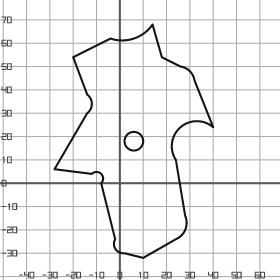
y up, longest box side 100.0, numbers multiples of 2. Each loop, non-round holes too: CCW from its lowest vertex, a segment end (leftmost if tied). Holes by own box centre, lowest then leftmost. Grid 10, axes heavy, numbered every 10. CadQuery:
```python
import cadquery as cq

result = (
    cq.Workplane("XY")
    .moveTo(10.0, -32.0)
    .lineTo(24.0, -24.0)
    .threePointArc((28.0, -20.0), (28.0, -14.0))
    .lineTo(24.0, 10.0)
    .threePointArc((26.0, 24.0), (40.0, 24.0))
    .lineTo(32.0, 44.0)
    .threePointArc((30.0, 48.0), (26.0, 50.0))
    .lineTo(18.0, 54.0)
    .lineTo(14.0, 68.0)
    .threePointArc((6.0, 62.0), (-4.0, 62.0))
    .lineTo(-20.0, 54.0)
    .lineTo(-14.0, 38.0)
    .threePointArc((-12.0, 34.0), (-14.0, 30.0))
    .lineTo(-28.0, 6.0)
    .lineTo(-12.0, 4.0)
    .threePointArc((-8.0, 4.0), (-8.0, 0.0))
    .lineTo(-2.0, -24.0)
    .threePointArc((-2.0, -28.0), (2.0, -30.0))
    .close()
    .moveTo(6.0, 18.0)
    .circle(4.0)
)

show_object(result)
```